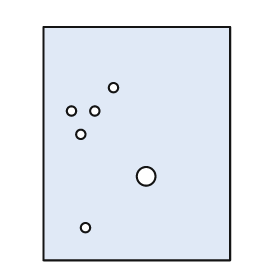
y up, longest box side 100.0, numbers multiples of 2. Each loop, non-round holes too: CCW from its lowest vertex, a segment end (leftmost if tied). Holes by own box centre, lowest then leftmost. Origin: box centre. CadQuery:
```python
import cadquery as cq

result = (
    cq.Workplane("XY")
    .moveTo(-40.0, -50.0)
    .lineTo(40.0, -50.0)
    .lineTo(40.0, 50.0)
    .lineTo(-40.0, 50.0)
    .close()
    .moveTo(-22.0, -36.0)
    .circle(2.0)
    .moveTo(4.0, -14.0)
    .circle(4.0)
    .moveTo(-24.0, 4.0)
    .circle(2.0)
    .moveTo(-28.0, 14.0)
    .circle(2.0)
    .moveTo(-18.0, 14.0)
    .circle(2.0)
    .moveTo(-10.0, 24.0)
    .circle(2.0)
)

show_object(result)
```